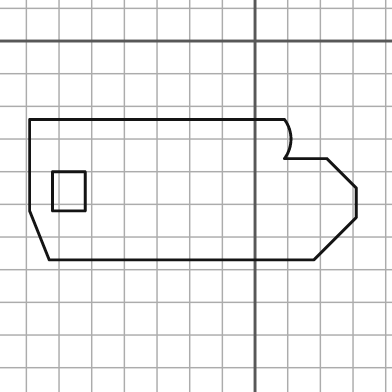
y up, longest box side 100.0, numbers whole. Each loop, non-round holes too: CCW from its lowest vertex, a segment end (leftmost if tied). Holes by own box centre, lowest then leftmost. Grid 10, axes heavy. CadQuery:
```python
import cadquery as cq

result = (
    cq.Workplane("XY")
    .moveTo(-63.0, -67.0)
    .lineTo(18.0, -67.0)
    .lineTo(31.0, -54.0)
    .lineTo(31.0, -45.0)
    .lineTo(22.0, -36.0)
    .lineTo(9.0, -36.0)
    .threePointArc((11.0, -30.0), (9.0, -24.0))
    .lineTo(-69.0, -24.0)
    .lineTo(-69.0, -52.0)
    .close()
    .moveTo(-62.0, -52.0)
    .lineTo(-52.0, -52.0)
    .lineTo(-52.0, -40.0)
    .lineTo(-62.0, -40.0)
    .close()
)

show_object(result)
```